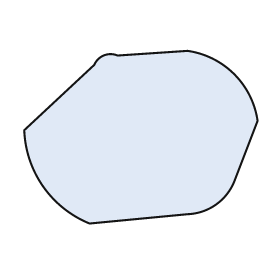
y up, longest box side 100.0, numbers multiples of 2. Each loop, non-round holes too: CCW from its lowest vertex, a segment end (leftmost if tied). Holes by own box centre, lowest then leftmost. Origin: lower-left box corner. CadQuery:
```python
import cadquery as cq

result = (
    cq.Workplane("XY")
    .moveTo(28.0, 0.0)
    .lineTo(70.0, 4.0)
    .threePointArc((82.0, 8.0), (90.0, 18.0))
    .lineTo(100.0, 44.0)
    .threePointArc((90.0, 64.0), (70.0, 74.0))
    .lineTo(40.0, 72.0)
    .threePointArc((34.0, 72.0), (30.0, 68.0))
    .lineTo(0.0, 40.0)
    .threePointArc((8.0, 16.0), (28.0, 0.0))
    .close()
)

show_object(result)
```